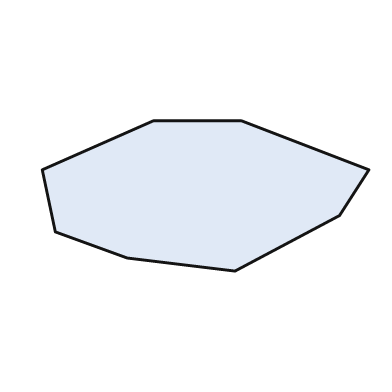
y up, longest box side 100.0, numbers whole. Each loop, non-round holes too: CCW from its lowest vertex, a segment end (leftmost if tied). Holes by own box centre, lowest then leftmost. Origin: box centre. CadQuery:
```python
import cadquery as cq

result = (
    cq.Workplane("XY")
    .moveTo(9.0, -23.0)
    .lineTo(41.0, -6.0)
    .lineTo(50.0, 8.0)
    .lineTo(11.0, 23.0)
    .lineTo(-16.0, 23.0)
    .lineTo(-50.0, 8.0)
    .lineTo(-46.0, -11.0)
    .lineTo(-24.0, -19.0)
    .close()
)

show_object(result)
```